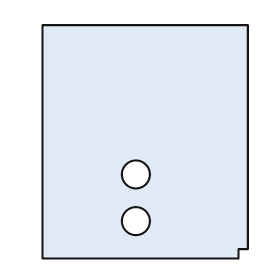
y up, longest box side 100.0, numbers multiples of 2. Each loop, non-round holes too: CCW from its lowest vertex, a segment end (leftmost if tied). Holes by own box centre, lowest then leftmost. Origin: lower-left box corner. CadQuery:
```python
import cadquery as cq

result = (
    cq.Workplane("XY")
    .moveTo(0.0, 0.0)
    .lineTo(84.0, 0.0)
    .lineTo(84.0, 4.0)
    .lineTo(88.0, 4.0)
    .lineTo(88.0, 100.0)
    .lineTo(0.0, 100.0)
    .close()
    .moveTo(40.0, 16.0)
    .circle(6.0)
    .moveTo(40.0, 36.0)
    .circle(6.0)
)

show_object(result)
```